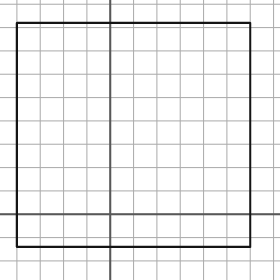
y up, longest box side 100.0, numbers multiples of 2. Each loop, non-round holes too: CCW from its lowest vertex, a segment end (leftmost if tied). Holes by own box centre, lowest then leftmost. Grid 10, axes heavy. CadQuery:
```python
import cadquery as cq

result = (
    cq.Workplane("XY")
    .moveTo(-40.0, -14.0)
    .lineTo(60.0, -14.0)
    .lineTo(60.0, 82.0)
    .lineTo(-40.0, 82.0)
    .close()
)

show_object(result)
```